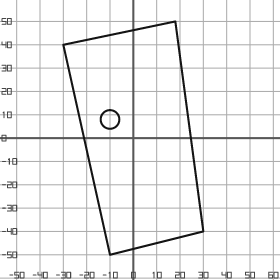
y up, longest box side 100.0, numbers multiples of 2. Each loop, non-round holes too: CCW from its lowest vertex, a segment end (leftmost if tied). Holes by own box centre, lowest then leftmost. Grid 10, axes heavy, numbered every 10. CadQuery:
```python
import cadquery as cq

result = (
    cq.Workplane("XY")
    .moveTo(-10.0, -50.0)
    .lineTo(30.0, -40.0)
    .lineTo(18.0, 50.0)
    .lineTo(-30.0, 40.0)
    .close()
    .moveTo(-10.0, 8.0)
    .circle(4.0)
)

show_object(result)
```